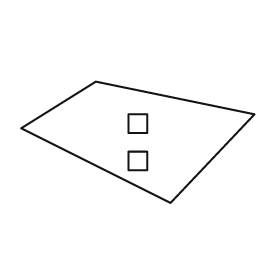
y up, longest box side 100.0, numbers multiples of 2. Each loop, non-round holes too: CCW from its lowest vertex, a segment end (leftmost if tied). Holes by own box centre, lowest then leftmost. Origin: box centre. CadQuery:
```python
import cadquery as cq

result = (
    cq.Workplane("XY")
    .moveTo(14.0, -26.0)
    .lineTo(50.0, 12.0)
    .lineTo(-18.0, 26.0)
    .lineTo(-50.0, 6.0)
    .close()
    .moveTo(-4.0, -12.0)
    .lineTo(4.0, -12.0)
    .lineTo(4.0, -4.0)
    .lineTo(-4.0, -4.0)
    .close()
    .moveTo(-4.0, 4.0)
    .lineTo(4.0, 4.0)
    .lineTo(4.0, 12.0)
    .lineTo(-4.0, 12.0)
    .close()
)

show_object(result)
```